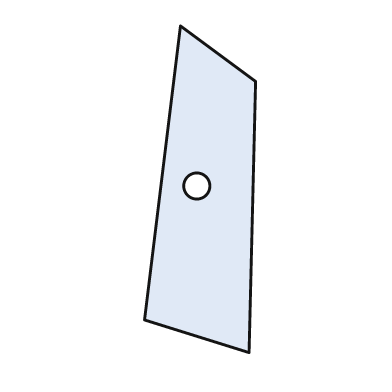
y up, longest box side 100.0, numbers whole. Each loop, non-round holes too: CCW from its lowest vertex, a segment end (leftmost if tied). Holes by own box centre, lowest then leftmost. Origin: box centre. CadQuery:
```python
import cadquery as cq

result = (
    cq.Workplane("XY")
    .moveTo(15.0, -50.0)
    .lineTo(17.0, 33.0)
    .lineTo(-6.0, 50.0)
    .lineTo(-17.0, -40.0)
    .close()
    .moveTo(-1.0, 1.0)
    .circle(4.0)
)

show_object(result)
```